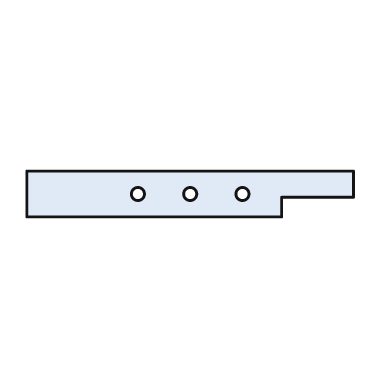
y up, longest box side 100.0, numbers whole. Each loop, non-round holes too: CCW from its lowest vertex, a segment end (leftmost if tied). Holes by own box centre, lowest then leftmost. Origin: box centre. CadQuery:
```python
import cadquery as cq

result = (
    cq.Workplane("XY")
    .moveTo(-50.0, -7.0)
    .lineTo(28.0, -7.0)
    .lineTo(28.0, -1.0)
    .lineTo(50.0, -1.0)
    .lineTo(50.0, 7.0)
    .lineTo(-50.0, 7.0)
    .close()
    .moveTo(-16.0, 0.0)
    .circle(2.0)
    .moveTo(0.0, 0.0)
    .circle(2.0)
    .moveTo(16.0, 0.0)
    .circle(2.0)
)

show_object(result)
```